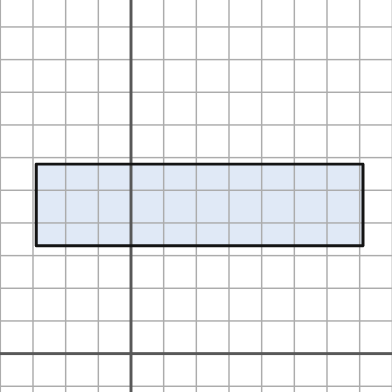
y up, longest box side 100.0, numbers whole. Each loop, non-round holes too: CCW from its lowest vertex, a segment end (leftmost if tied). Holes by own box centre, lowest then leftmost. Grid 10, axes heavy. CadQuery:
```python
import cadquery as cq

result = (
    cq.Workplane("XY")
    .moveTo(-29.0, 33.0)
    .lineTo(71.0, 33.0)
    .lineTo(71.0, 58.0)
    .lineTo(-29.0, 58.0)
    .close()
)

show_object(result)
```